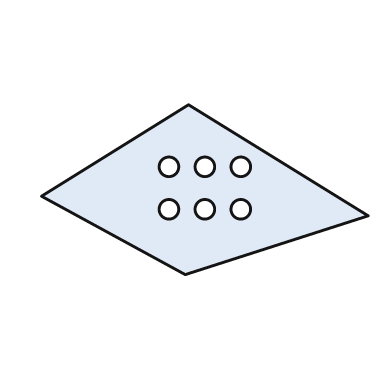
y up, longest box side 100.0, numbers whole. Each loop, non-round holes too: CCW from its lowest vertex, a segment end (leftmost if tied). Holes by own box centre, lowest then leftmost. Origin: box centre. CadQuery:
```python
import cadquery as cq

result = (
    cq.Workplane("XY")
    .moveTo(-6.0, -26.0)
    .lineTo(50.0, -8.0)
    .lineTo(-5.0, 26.0)
    .lineTo(-50.0, -2.0)
    .close()
    .moveTo(-11.0, -6.0)
    .circle(3.0)
    .moveTo(0.0, -6.0)
    .circle(3.0)
    .moveTo(11.0, -6.0)
    .circle(3.0)
    .moveTo(-11.0, 7.0)
    .circle(3.0)
    .moveTo(0.0, 7.0)
    .circle(3.0)
    .moveTo(11.0, 7.0)
    .circle(3.0)
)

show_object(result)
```